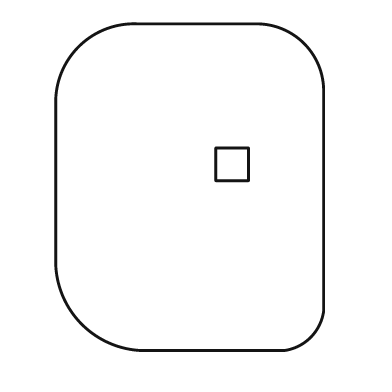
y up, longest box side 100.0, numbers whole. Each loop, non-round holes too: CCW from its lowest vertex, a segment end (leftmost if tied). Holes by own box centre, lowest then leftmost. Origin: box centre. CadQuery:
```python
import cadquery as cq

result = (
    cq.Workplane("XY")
    .moveTo(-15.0, -50.0)
    .lineTo(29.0, -50.0)
    .threePointArc((37.0, -46.0), (41.0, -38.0))
    .lineTo(41.0, 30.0)
    .threePointArc((35.0, 44.0), (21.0, 50.0))
    .lineTo(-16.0, 50.0)
    .threePointArc((-34.0, 43.0), (-41.0, 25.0))
    .lineTo(-41.0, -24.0)
    .threePointArc((-33.0, -42.0), (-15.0, -50.0))
    .close()
    .moveTo(8.0, 2.0)
    .lineTo(18.0, 2.0)
    .lineTo(18.0, 12.0)
    .lineTo(8.0, 12.0)
    .close()
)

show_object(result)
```